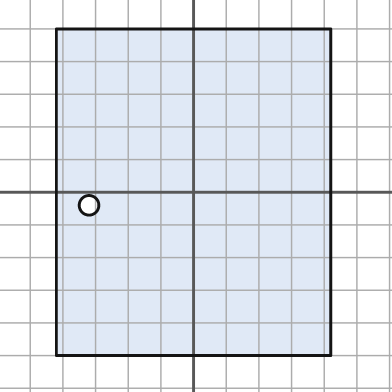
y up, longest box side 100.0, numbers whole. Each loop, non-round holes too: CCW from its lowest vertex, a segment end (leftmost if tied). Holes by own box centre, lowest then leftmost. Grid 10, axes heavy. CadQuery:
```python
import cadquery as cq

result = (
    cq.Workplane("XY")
    .moveTo(-42.0, -50.0)
    .lineTo(42.0, -50.0)
    .lineTo(42.0, 50.0)
    .lineTo(-42.0, 50.0)
    .close()
    .moveTo(-32.0, -4.0)
    .circle(3.0)
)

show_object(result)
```